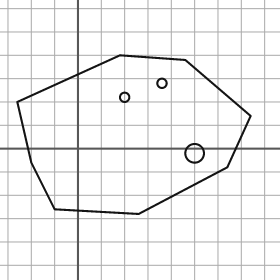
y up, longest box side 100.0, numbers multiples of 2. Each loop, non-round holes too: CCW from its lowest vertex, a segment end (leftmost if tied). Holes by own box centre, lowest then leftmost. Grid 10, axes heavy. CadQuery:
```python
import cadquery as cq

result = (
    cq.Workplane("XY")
    .moveTo(26.0, -28.0)
    .lineTo(64.0, -8.0)
    .lineTo(74.0, 14.0)
    .lineTo(46.0, 38.0)
    .lineTo(18.0, 40.0)
    .lineTo(-26.0, 20.0)
    .lineTo(-20.0, -6.0)
    .lineTo(-10.0, -26.0)
    .close()
    .moveTo(50.0, -2.0)
    .circle(4.0)
    .moveTo(20.0, 22.0)
    .circle(2.0)
    .moveTo(36.0, 28.0)
    .circle(2.0)
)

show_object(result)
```